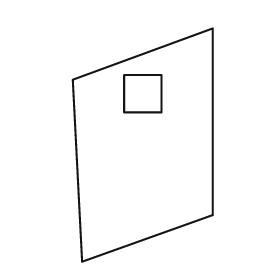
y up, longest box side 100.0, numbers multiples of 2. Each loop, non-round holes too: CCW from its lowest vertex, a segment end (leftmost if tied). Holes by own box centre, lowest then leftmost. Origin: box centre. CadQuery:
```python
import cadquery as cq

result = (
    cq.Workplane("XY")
    .moveTo(-26.0, -50.0)
    .lineTo(30.0, -30.0)
    .lineTo(30.0, 50.0)
    .lineTo(-30.0, 28.0)
    .close()
    .moveTo(-8.0, 14.0)
    .lineTo(8.0, 14.0)
    .lineTo(8.0, 30.0)
    .lineTo(-8.0, 30.0)
    .close()
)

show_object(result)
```